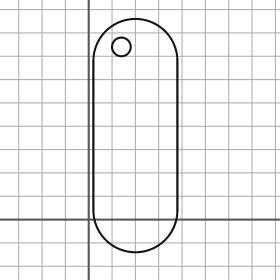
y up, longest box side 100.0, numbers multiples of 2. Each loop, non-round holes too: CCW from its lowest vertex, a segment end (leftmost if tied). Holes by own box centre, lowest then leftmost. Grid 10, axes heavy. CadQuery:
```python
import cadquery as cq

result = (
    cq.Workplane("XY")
    .moveTo(2.0, 4.0)
    .threePointArc((20.0, -14.0), (38.0, 4.0))
    .lineTo(38.0, 68.0)
    .threePointArc((20.0, 86.0), (2.0, 68.0))
    .close()
    .moveTo(14.0, 74.0)
    .circle(4.0)
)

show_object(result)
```